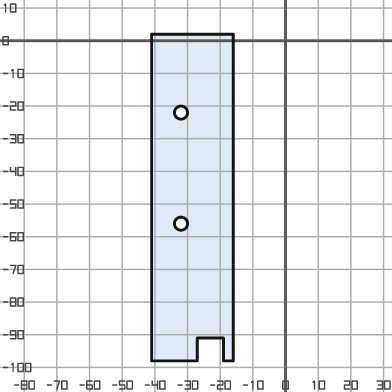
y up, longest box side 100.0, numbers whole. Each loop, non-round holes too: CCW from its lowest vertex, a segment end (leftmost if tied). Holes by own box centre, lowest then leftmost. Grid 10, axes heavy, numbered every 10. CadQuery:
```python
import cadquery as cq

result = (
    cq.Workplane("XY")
    .moveTo(-41.0, -98.0)
    .lineTo(-27.0, -98.0)
    .lineTo(-27.0, -91.0)
    .lineTo(-19.0, -91.0)
    .lineTo(-19.0, -98.0)
    .lineTo(-16.0, -98.0)
    .lineTo(-16.0, 2.0)
    .lineTo(-41.0, 2.0)
    .close()
    .moveTo(-32.0, -56.0)
    .circle(2.0)
    .moveTo(-32.0, -22.0)
    .circle(2.0)
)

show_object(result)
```